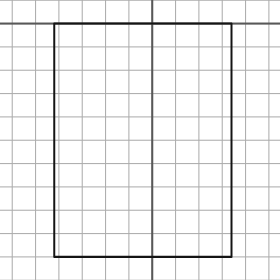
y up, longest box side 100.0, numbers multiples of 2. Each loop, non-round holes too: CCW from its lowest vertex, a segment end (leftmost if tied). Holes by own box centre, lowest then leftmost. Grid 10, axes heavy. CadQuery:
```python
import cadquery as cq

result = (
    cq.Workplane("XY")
    .moveTo(-42.0, -100.0)
    .lineTo(34.0, -100.0)
    .lineTo(34.0, 0.0)
    .lineTo(-42.0, 0.0)
    .close()
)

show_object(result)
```